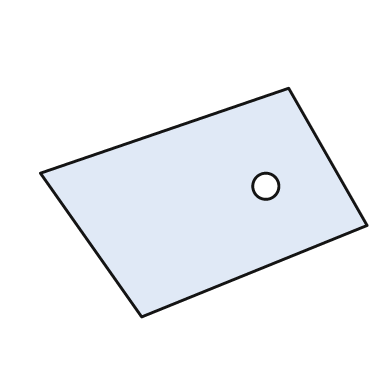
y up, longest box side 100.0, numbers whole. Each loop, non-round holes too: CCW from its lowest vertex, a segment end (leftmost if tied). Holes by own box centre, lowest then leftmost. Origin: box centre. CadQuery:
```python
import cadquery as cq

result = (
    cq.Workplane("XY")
    .moveTo(-19.0, -35.0)
    .lineTo(50.0, -7.0)
    .lineTo(26.0, 35.0)
    .lineTo(-50.0, 9.0)
    .close()
    .moveTo(19.0, 5.0)
    .circle(4.0)
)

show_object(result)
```